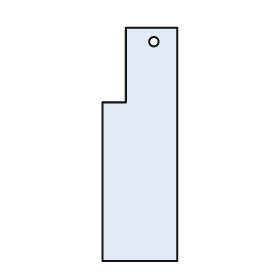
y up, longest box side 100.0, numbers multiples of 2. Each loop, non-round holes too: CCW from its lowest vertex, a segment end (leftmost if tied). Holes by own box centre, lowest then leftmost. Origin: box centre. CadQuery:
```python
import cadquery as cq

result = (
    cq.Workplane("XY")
    .moveTo(-16.0, -50.0)
    .lineTo(16.0, -50.0)
    .lineTo(16.0, 50.0)
    .lineTo(-6.0, 50.0)
    .lineTo(-6.0, 18.0)
    .lineTo(-16.0, 18.0)
    .close()
    .moveTo(6.0, 44.0)
    .circle(2.0)
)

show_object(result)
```